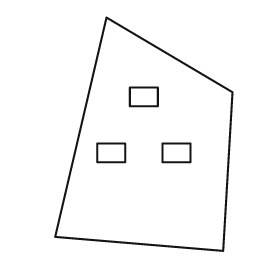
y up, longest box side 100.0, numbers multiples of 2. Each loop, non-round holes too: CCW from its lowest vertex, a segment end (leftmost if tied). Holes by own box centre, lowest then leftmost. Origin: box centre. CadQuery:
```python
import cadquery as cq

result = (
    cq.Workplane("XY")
    .moveTo(34.0, -50.0)
    .lineTo(38.0, 18.0)
    .lineTo(-16.0, 50.0)
    .lineTo(-38.0, -44.0)
    .close()
    .moveTo(-20.0, -12.0)
    .lineTo(-8.0, -12.0)
    .lineTo(-8.0, -4.0)
    .lineTo(-20.0, -4.0)
    .close()
    .moveTo(8.0, -12.0)
    .lineTo(20.0, -12.0)
    .lineTo(20.0, -4.0)
    .lineTo(8.0, -4.0)
    .close()
    .moveTo(-6.0, 12.0)
    .lineTo(6.0, 12.0)
    .lineTo(6.0, 20.0)
    .lineTo(-6.0, 20.0)
    .close()
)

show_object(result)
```